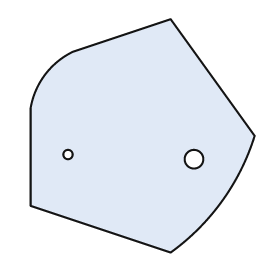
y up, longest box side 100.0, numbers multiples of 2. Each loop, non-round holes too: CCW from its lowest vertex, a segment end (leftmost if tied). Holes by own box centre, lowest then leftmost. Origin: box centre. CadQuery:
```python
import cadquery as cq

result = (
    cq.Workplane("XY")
    .moveTo(12.0, -50.0)
    .threePointArc((34.0, -28.0), (48.0, 0.0))
    .lineTo(12.0, 50.0)
    .lineTo(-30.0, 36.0)
    .threePointArc((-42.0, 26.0), (-48.0, 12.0))
    .lineTo(-48.0, -30.0)
    .close()
    .moveTo(22.0, -10.0)
    .circle(4.0)
    .moveTo(-32.0, -8.0)
    .circle(2.0)
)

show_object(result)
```